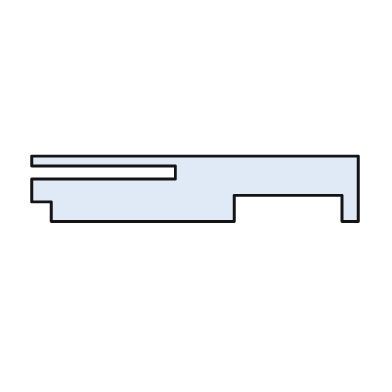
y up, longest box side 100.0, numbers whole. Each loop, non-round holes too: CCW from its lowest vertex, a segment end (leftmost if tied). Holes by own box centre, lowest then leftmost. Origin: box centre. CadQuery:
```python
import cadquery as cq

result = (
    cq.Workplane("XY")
    .moveTo(-44.0, -10.0)
    .lineTo(12.0, -10.0)
    .lineTo(12.0, -2.0)
    .lineTo(45.0, -2.0)
    .lineTo(45.0, -10.0)
    .lineTo(50.0, -10.0)
    .lineTo(50.0, 10.0)
    .lineTo(-50.0, 10.0)
    .lineTo(-50.0, 7.0)
    .lineTo(-6.0, 7.0)
    .lineTo(-6.0, 3.0)
    .lineTo(-50.0, 3.0)
    .lineTo(-50.0, -4.0)
    .lineTo(-44.0, -4.0)
    .close()
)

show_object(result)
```